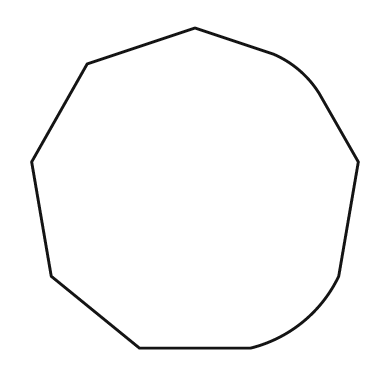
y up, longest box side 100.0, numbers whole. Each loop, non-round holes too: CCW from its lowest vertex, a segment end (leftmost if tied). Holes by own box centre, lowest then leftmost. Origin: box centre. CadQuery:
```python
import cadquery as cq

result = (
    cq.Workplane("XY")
    .moveTo(-17.0, -49.0)
    .lineTo(17.0, -49.0)
    .threePointArc((33.0, -41.0), (44.0, -27.0))
    .lineTo(50.0, 8.0)
    .lineTo(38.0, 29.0)
    .threePointArc((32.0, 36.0), (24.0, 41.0))
    .lineTo(0.0, 49.0)
    .lineTo(-33.0, 38.0)
    .lineTo(-50.0, 8.0)
    .lineTo(-44.0, -27.0)
    .close()
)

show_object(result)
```